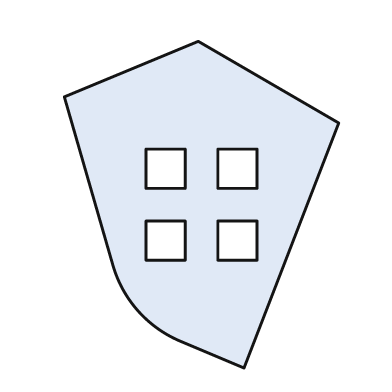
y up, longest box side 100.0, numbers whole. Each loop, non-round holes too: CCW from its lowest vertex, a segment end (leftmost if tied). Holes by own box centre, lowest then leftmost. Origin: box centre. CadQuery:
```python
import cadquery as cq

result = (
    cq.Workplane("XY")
    .moveTo(13.0, -50.0)
    .lineTo(42.0, 25.0)
    .lineTo(-1.0, 50.0)
    .lineTo(-42.0, 33.0)
    .lineTo(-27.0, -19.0)
    .threePointArc((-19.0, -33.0), (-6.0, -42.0))
    .close()
    .moveTo(-17.0, -17.0)
    .lineTo(-5.0, -17.0)
    .lineTo(-5.0, -5.0)
    .lineTo(-17.0, -5.0)
    .close()
    .moveTo(5.0, -17.0)
    .lineTo(17.0, -17.0)
    .lineTo(17.0, -5.0)
    .lineTo(5.0, -5.0)
    .close()
    .moveTo(-17.0, 5.0)
    .lineTo(-5.0, 5.0)
    .lineTo(-5.0, 17.0)
    .lineTo(-17.0, 17.0)
    .close()
    .moveTo(5.0, 5.0)
    .lineTo(17.0, 5.0)
    .lineTo(17.0, 17.0)
    .lineTo(5.0, 17.0)
    .close()
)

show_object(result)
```